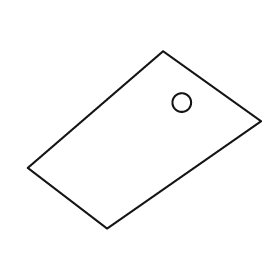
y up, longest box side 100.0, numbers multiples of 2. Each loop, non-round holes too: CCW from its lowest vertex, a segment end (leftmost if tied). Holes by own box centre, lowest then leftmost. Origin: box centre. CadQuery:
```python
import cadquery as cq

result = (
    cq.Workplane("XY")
    .moveTo(-16.0, -38.0)
    .lineTo(50.0, 8.0)
    .lineTo(8.0, 38.0)
    .lineTo(-50.0, -12.0)
    .close()
    .moveTo(16.0, 16.0)
    .circle(4.0)
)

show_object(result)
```